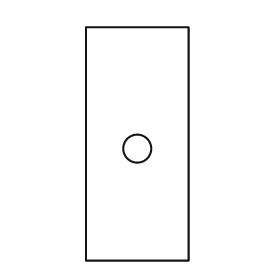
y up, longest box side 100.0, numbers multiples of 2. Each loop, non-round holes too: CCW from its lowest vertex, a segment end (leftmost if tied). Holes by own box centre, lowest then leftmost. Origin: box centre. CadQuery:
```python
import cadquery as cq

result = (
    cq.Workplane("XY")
    .moveTo(-22.0, -50.0)
    .lineTo(22.0, -50.0)
    .lineTo(22.0, 50.0)
    .lineTo(-22.0, 50.0)
    .close()
    .moveTo(0.0, -2.0)
    .circle(6.0)
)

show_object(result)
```